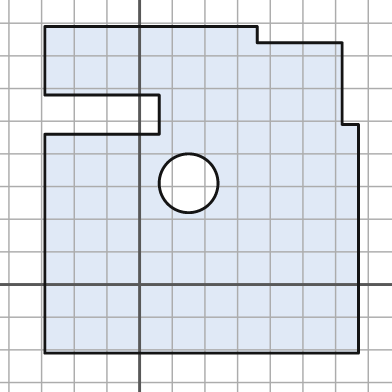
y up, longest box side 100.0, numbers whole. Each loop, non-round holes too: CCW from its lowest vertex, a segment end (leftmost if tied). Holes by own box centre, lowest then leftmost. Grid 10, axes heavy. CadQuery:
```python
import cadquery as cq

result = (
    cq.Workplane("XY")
    .moveTo(-29.0, -21.0)
    .lineTo(67.0, -21.0)
    .lineTo(67.0, 49.0)
    .lineTo(62.0, 49.0)
    .lineTo(62.0, 74.0)
    .lineTo(36.0, 74.0)
    .lineTo(36.0, 79.0)
    .lineTo(-29.0, 79.0)
    .lineTo(-29.0, 58.0)
    .lineTo(6.0, 58.0)
    .lineTo(6.0, 46.0)
    .lineTo(-29.0, 46.0)
    .close()
    .moveTo(15.0, 31.0)
    .circle(9.0)
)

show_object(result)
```